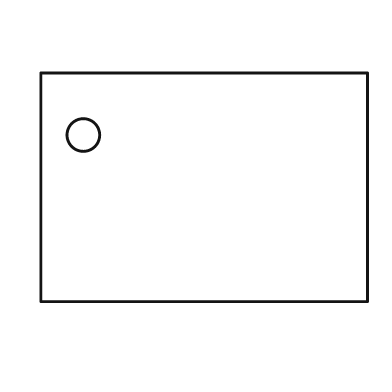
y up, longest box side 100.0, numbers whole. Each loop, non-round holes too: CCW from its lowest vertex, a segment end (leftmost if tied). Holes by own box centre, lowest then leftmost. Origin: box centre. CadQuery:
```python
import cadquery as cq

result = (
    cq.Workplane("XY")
    .moveTo(-50.0, -35.0)
    .lineTo(50.0, -35.0)
    .lineTo(50.0, 35.0)
    .lineTo(-50.0, 35.0)
    .close()
    .moveTo(-37.0, 16.0)
    .circle(5.0)
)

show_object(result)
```